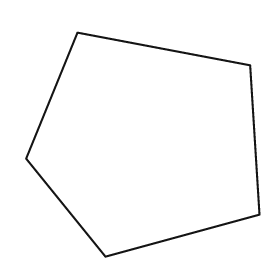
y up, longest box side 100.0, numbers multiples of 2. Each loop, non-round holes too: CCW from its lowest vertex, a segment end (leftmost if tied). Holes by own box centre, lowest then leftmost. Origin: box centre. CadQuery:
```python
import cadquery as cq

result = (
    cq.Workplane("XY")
    .moveTo(-16.0, -48.0)
    .lineTo(50.0, -30.0)
    .lineTo(46.0, 34.0)
    .lineTo(-28.0, 48.0)
    .lineTo(-50.0, -6.0)
    .close()
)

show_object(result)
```